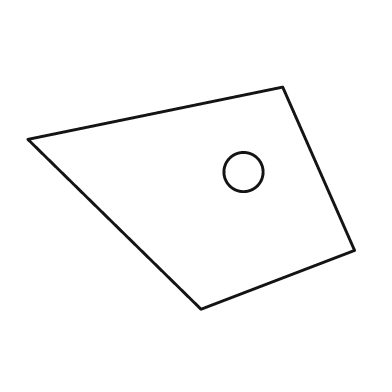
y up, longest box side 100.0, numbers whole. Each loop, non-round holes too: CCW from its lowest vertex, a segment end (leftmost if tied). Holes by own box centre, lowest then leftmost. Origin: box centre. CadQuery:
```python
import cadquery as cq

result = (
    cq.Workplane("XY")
    .moveTo(3.0, -34.0)
    .lineTo(50.0, -16.0)
    .lineTo(28.0, 34.0)
    .lineTo(-50.0, 18.0)
    .close()
    .moveTo(16.0, 8.0)
    .circle(6.0)
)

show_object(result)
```